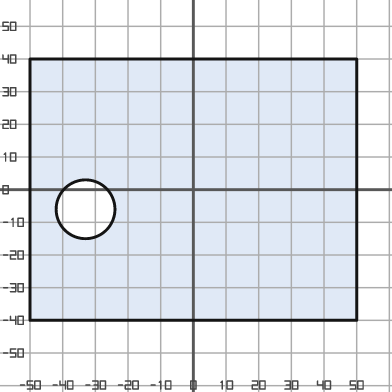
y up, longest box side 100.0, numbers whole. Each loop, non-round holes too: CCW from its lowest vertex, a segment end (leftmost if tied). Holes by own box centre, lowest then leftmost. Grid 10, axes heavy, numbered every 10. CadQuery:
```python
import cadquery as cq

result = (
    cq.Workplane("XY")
    .moveTo(-50.0, -40.0)
    .lineTo(50.0, -40.0)
    .lineTo(50.0, 40.0)
    .lineTo(-50.0, 40.0)
    .close()
    .moveTo(-33.0, -6.0)
    .circle(9.0)
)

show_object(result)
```